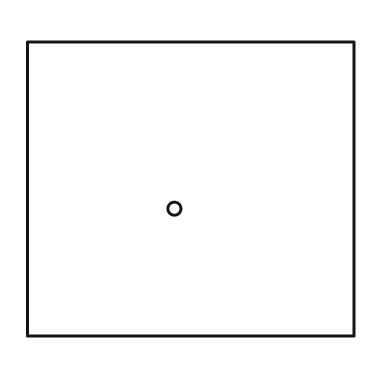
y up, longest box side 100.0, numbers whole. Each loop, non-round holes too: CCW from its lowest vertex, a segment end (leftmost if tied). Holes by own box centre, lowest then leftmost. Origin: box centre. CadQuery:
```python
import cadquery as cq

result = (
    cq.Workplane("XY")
    .moveTo(-50.0, -45.0)
    .lineTo(50.0, -45.0)
    .lineTo(50.0, 45.0)
    .lineTo(-50.0, 45.0)
    .close()
    .moveTo(-5.0, -6.0)
    .circle(2.0)
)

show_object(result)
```